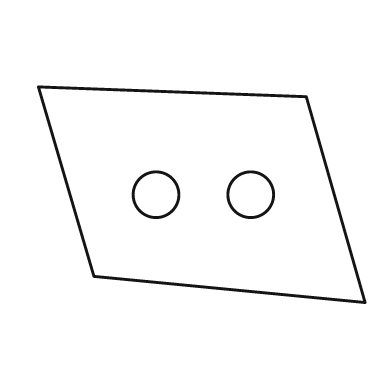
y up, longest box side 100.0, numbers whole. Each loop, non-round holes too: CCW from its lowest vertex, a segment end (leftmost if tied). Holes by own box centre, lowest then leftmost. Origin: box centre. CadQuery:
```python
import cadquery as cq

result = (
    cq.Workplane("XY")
    .moveTo(50.0, -33.0)
    .lineTo(32.0, 30.0)
    .lineTo(-50.0, 33.0)
    .lineTo(-33.0, -25.0)
    .close()
    .moveTo(-14.0, 0.0)
    .circle(7.0)
    .moveTo(15.0, 0.0)
    .circle(7.0)
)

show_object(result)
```